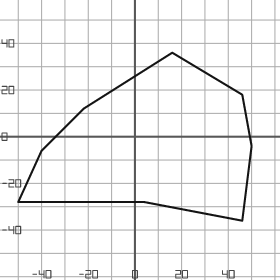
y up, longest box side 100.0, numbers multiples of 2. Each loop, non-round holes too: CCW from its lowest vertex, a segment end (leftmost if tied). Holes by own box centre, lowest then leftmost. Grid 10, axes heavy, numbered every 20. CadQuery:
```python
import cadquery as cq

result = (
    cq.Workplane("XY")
    .moveTo(46.0, -36.0)
    .lineTo(50.0, -4.0)
    .lineTo(46.0, 18.0)
    .lineTo(16.0, 36.0)
    .lineTo(-22.0, 12.0)
    .lineTo(-40.0, -6.0)
    .lineTo(-50.0, -28.0)
    .lineTo(4.0, -28.0)
    .close()
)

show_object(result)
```